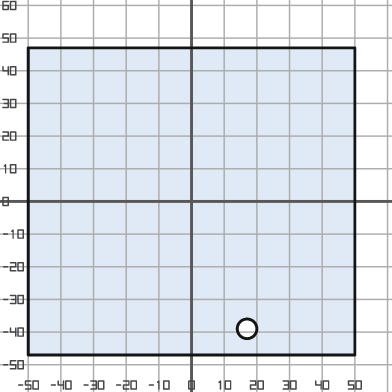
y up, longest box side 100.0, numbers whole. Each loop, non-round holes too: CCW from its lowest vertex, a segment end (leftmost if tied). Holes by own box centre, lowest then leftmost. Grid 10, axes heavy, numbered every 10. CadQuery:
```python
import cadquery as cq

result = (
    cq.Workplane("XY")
    .moveTo(-50.0, -47.0)
    .lineTo(50.0, -47.0)
    .lineTo(50.0, 47.0)
    .lineTo(-50.0, 47.0)
    .close()
    .moveTo(17.0, -39.0)
    .circle(3.0)
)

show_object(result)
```